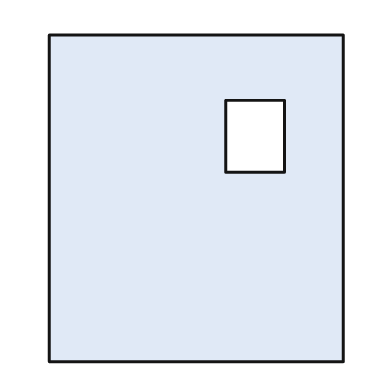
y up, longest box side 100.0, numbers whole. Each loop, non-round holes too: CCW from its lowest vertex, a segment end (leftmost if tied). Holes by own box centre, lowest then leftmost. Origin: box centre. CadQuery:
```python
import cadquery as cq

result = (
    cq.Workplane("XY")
    .moveTo(-45.0, -50.0)
    .lineTo(45.0, -50.0)
    .lineTo(45.0, 50.0)
    .lineTo(-45.0, 50.0)
    .close()
    .moveTo(9.0, 8.0)
    .lineTo(27.0, 8.0)
    .lineTo(27.0, 30.0)
    .lineTo(9.0, 30.0)
    .close()
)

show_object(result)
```